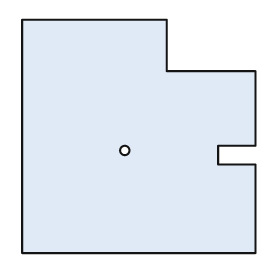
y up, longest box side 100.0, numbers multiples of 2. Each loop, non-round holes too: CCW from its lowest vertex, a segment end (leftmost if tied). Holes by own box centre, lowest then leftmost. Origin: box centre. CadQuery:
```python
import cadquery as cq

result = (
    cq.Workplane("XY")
    .moveTo(-50.0, -50.0)
    .lineTo(50.0, -50.0)
    .lineTo(50.0, -12.0)
    .lineTo(34.0, -12.0)
    .lineTo(34.0, -4.0)
    .lineTo(50.0, -4.0)
    .lineTo(50.0, 28.0)
    .lineTo(12.0, 28.0)
    .lineTo(12.0, 50.0)
    .lineTo(-50.0, 50.0)
    .close()
    .moveTo(-6.0, -6.0)
    .circle(2.0)
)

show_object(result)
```